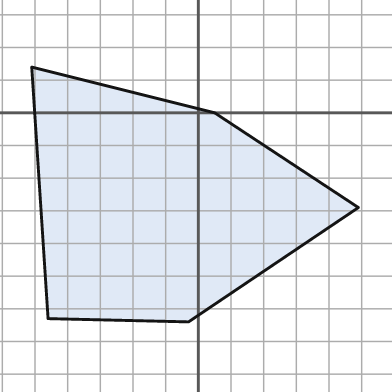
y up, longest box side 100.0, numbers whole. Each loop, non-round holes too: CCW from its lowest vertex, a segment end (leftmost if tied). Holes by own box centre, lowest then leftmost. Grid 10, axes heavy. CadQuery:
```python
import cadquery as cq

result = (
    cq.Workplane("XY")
    .moveTo(-3.0, -64.0)
    .lineTo(49.0, -29.0)
    .lineTo(5.0, 0.0)
    .lineTo(-51.0, 14.0)
    .lineTo(-46.0, -63.0)
    .close()
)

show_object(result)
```